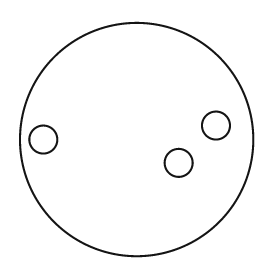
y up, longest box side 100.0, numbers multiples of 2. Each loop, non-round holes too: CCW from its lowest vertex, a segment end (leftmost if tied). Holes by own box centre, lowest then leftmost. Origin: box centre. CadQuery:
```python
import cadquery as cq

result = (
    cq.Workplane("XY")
    .moveTo(0.0, 0.0)
    .circle(50.0)
    .moveTo(18.0, -10.0)
    .circle(6.0)
    .moveTo(-40.0, 0.0)
    .circle(6.0)
    .moveTo(34.0, 6.0)
    .circle(6.0)
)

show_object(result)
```